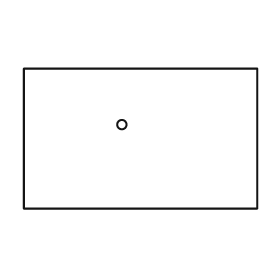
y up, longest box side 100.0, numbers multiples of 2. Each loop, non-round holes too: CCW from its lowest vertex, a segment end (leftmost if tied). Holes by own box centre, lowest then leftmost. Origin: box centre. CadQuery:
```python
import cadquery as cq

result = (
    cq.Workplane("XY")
    .moveTo(-50.0, -30.0)
    .lineTo(50.0, -30.0)
    .lineTo(50.0, 30.0)
    .lineTo(-50.0, 30.0)
    .close()
    .moveTo(-8.0, 6.0)
    .circle(2.0)
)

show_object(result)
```